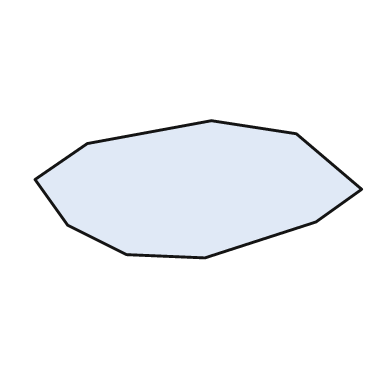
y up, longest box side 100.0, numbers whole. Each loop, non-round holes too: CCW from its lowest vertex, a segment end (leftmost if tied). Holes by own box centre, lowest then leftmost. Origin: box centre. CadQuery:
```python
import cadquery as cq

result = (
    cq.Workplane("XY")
    .moveTo(2.0, -21.0)
    .lineTo(36.0, -10.0)
    .lineTo(50.0, 0.0)
    .lineTo(30.0, 17.0)
    .lineTo(4.0, 21.0)
    .lineTo(-34.0, 14.0)
    .lineTo(-50.0, 3.0)
    .lineTo(-40.0, -11.0)
    .lineTo(-22.0, -20.0)
    .close()
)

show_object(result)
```